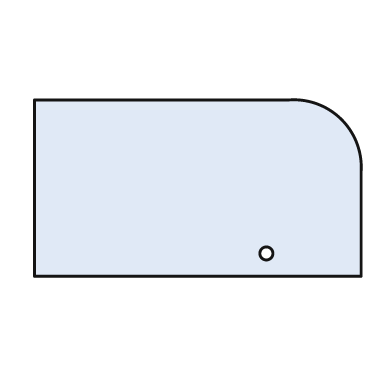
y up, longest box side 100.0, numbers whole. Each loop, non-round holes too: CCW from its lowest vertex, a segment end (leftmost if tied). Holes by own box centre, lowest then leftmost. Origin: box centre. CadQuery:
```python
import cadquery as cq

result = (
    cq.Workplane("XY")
    .moveTo(-50.0, -27.0)
    .lineTo(50.0, -27.0)
    .lineTo(50.0, 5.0)
    .threePointArc((44.0, 21.0), (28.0, 27.0))
    .lineTo(-50.0, 27.0)
    .close()
    .moveTo(21.0, -20.0)
    .circle(2.0)
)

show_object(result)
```